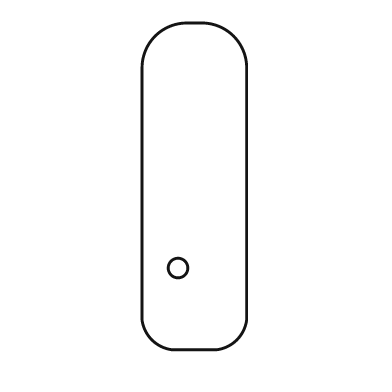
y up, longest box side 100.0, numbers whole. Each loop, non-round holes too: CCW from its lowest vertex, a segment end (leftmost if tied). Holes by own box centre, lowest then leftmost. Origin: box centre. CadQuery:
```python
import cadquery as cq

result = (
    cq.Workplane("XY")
    .moveTo(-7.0, -50.0)
    .lineTo(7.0, -50.0)
    .threePointArc((13.0, -47.0), (16.0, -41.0))
    .lineTo(16.0, 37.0)
    .threePointArc((12.0, 46.0), (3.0, 50.0))
    .lineTo(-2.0, 50.0)
    .threePointArc((-12.0, 46.0), (-16.0, 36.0))
    .lineTo(-16.0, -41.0)
    .threePointArc((-13.0, -47.0), (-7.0, -50.0))
    .close()
    .moveTo(-5.0, -25.0)
    .circle(3.0)
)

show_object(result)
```